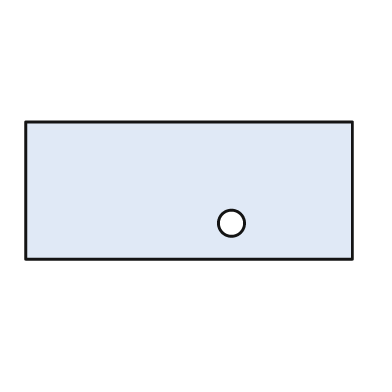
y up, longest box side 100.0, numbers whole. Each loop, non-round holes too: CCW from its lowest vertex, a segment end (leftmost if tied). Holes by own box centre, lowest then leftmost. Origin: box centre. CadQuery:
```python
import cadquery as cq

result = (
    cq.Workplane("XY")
    .moveTo(-50.0, -21.0)
    .lineTo(50.0, -21.0)
    .lineTo(50.0, 21.0)
    .lineTo(-50.0, 21.0)
    .close()
    .moveTo(13.0, -10.0)
    .circle(4.0)
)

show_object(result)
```